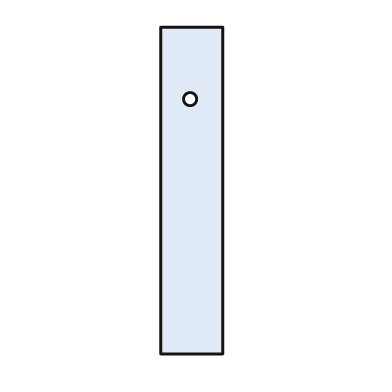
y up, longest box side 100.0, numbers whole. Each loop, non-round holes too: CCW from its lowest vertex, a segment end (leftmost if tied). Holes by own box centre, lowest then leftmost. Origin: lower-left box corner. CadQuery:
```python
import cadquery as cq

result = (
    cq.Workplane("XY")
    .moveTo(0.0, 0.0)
    .lineTo(19.0, 0.0)
    .lineTo(19.0, 100.0)
    .lineTo(0.0, 100.0)
    .close()
    .moveTo(9.0, 78.0)
    .circle(2.0)
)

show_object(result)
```